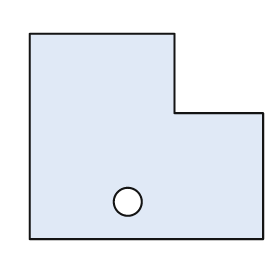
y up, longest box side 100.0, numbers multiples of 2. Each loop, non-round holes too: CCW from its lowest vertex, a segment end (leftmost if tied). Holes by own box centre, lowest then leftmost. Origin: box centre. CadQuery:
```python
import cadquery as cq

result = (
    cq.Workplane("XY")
    .moveTo(-50.0, -44.0)
    .lineTo(50.0, -44.0)
    .lineTo(50.0, 10.0)
    .lineTo(12.0, 10.0)
    .lineTo(12.0, 44.0)
    .lineTo(-50.0, 44.0)
    .close()
    .moveTo(-8.0, -28.0)
    .circle(6.0)
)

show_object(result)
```